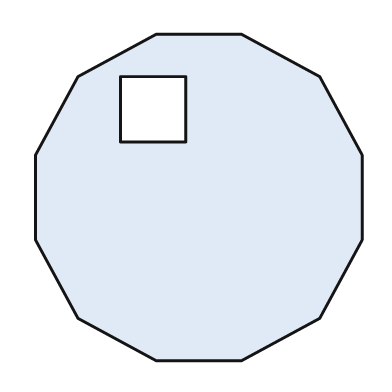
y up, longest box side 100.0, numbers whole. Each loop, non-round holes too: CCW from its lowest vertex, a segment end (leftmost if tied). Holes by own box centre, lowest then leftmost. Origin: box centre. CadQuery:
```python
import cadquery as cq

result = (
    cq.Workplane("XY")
    .moveTo(-13.0, -50.0)
    .lineTo(13.0, -50.0)
    .lineTo(37.0, -37.0)
    .lineTo(50.0, -13.0)
    .lineTo(50.0, 13.0)
    .lineTo(37.0, 37.0)
    .lineTo(13.0, 50.0)
    .lineTo(-13.0, 50.0)
    .lineTo(-37.0, 37.0)
    .lineTo(-50.0, 13.0)
    .lineTo(-50.0, -13.0)
    .lineTo(-37.0, -37.0)
    .close()
    .moveTo(-24.0, 17.0)
    .lineTo(-4.0, 17.0)
    .lineTo(-4.0, 37.0)
    .lineTo(-24.0, 37.0)
    .close()
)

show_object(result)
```